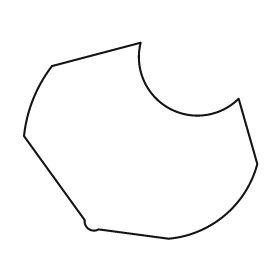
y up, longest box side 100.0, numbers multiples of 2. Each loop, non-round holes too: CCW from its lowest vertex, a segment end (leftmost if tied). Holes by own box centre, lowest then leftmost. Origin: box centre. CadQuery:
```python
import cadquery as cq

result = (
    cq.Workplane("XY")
    .moveTo(12.0, -42.0)
    .threePointArc((36.0, -32.0), (50.0, -10.0))
    .lineTo(42.0, 18.0)
    .threePointArc((12.0, 14.0), (0.0, 42.0))
    .lineTo(-38.0, 32.0)
    .threePointArc((-46.0, 18.0), (-50.0, 2.0))
    .lineTo(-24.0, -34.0)
    .threePointArc((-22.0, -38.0), (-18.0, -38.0))
    .close()
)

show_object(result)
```